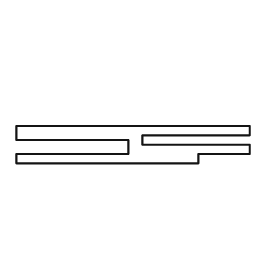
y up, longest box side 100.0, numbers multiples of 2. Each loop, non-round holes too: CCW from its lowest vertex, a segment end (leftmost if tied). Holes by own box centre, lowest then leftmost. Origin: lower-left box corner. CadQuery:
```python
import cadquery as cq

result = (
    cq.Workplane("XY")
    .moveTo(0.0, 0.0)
    .lineTo(78.0, 0.0)
    .lineTo(78.0, 4.0)
    .lineTo(100.0, 4.0)
    .lineTo(100.0, 8.0)
    .lineTo(54.0, 8.0)
    .lineTo(54.0, 12.0)
    .lineTo(100.0, 12.0)
    .lineTo(100.0, 16.0)
    .lineTo(0.0, 16.0)
    .lineTo(0.0, 10.0)
    .lineTo(48.0, 10.0)
    .lineTo(48.0, 4.0)
    .lineTo(0.0, 4.0)
    .close()
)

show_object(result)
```